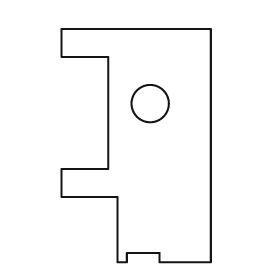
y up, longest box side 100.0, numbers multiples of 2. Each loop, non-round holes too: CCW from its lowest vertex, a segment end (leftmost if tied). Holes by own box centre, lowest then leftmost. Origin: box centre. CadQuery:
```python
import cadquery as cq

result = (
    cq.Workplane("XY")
    .moveTo(-8.0, -50.0)
    .lineTo(-4.0, -50.0)
    .lineTo(-4.0, -46.0)
    .lineTo(10.0, -46.0)
    .lineTo(10.0, -50.0)
    .lineTo(32.0, -50.0)
    .lineTo(32.0, 50.0)
    .lineTo(-32.0, 50.0)
    .lineTo(-32.0, 38.0)
    .lineTo(-12.0, 38.0)
    .lineTo(-12.0, -10.0)
    .lineTo(-32.0, -10.0)
    .lineTo(-32.0, -22.0)
    .lineTo(-8.0, -22.0)
    .close()
    .moveTo(6.0, 18.0)
    .circle(8.0)
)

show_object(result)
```